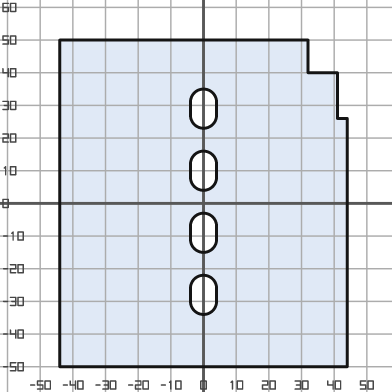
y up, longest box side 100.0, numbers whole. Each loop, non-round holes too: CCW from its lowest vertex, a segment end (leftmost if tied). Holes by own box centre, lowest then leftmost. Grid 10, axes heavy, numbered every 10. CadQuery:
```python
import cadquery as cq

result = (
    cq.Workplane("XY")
    .moveTo(-44.0, -50.0)
    .lineTo(44.0, -50.0)
    .lineTo(44.0, 26.0)
    .lineTo(41.0, 26.0)
    .lineTo(41.0, 40.0)
    .lineTo(32.0, 40.0)
    .lineTo(32.0, 50.0)
    .lineTo(-44.0, 50.0)
    .close()
    .moveTo(-4.0, -30.0)
    .threePointArc((0.0, -34.0), (4.0, -30.0))
    .lineTo(4.0, -26.0)
    .threePointArc((0.0, -22.0), (-4.0, -26.0))
    .close()
    .moveTo(-4.0, -11.0)
    .threePointArc((0.0, -15.0), (4.0, -11.0))
    .lineTo(4.0, -7.0)
    .threePointArc((0.0, -3.0), (-4.0, -7.0))
    .close()
    .moveTo(-4.0, 8.0)
    .threePointArc((0.0, 4.0), (4.0, 8.0))
    .lineTo(4.0, 12.0)
    .threePointArc((0.0, 16.0), (-4.0, 12.0))
    .close()
    .moveTo(-4.0, 27.0)
    .threePointArc((0.0, 23.0), (4.0, 27.0))
    .lineTo(4.0, 31.0)
    .threePointArc((0.0, 35.0), (-4.0, 31.0))
    .close()
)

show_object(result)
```